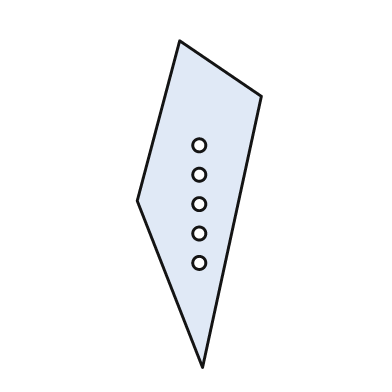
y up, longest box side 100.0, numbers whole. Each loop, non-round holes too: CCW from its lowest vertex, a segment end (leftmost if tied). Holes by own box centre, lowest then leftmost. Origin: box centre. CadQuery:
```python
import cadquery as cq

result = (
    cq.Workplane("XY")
    .moveTo(1.0, -50.0)
    .lineTo(19.0, 33.0)
    .lineTo(-6.0, 50.0)
    .lineTo(-19.0, 1.0)
    .close()
    .moveTo(0.0, -18.0)
    .circle(2.0)
    .moveTo(0.0, -9.0)
    .circle(2.0)
    .moveTo(0.0, 0.0)
    .circle(2.0)
    .moveTo(0.0, 9.0)
    .circle(2.0)
    .moveTo(0.0, 18.0)
    .circle(2.0)
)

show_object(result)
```